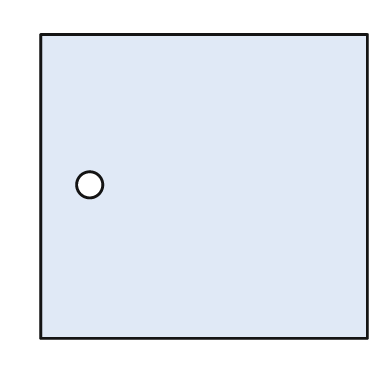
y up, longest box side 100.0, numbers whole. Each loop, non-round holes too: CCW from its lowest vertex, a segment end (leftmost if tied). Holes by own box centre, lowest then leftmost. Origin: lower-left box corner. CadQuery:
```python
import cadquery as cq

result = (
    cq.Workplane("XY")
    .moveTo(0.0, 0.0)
    .lineTo(100.0, 0.0)
    .lineTo(100.0, 93.0)
    .lineTo(0.0, 93.0)
    .close()
    .moveTo(15.0, 47.0)
    .circle(4.0)
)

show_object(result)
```